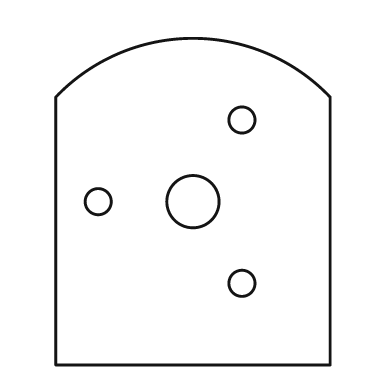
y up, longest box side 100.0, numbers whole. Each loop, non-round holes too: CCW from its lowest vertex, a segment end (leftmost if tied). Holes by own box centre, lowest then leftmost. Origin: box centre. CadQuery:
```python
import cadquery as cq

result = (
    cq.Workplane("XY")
    .moveTo(-42.0, -50.0)
    .lineTo(42.0, -50.0)
    .lineTo(42.0, 32.0)
    .threePointArc((0.0, 50.0), (-42.0, 32.0))
    .close()
    .moveTo(15.0, -25.0)
    .circle(4.0)
    .moveTo(-29.0, 0.0)
    .circle(4.0)
    .moveTo(0.0, 0.0)
    .circle(8.0)
    .moveTo(15.0, 25.0)
    .circle(4.0)
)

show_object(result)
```